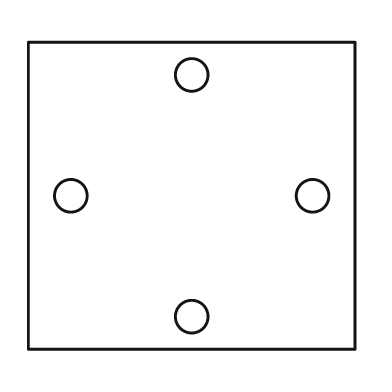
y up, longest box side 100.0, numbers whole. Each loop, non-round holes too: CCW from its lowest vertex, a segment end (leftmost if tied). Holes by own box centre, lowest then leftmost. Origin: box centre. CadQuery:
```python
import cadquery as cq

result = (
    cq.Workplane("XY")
    .moveTo(-50.0, -47.0)
    .lineTo(50.0, -47.0)
    .lineTo(50.0, 47.0)
    .lineTo(-50.0, 47.0)
    .close()
    .moveTo(0.0, -37.0)
    .circle(5.0)
    .moveTo(-37.0, 0.0)
    .circle(5.0)
    .moveTo(37.0, 0.0)
    .circle(5.0)
    .moveTo(0.0, 37.0)
    .circle(5.0)
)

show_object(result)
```